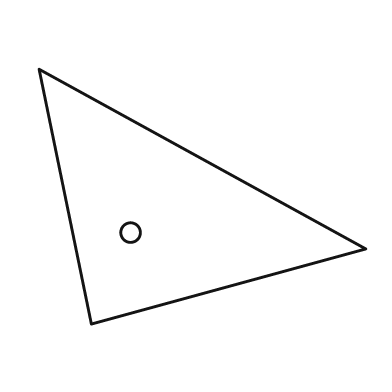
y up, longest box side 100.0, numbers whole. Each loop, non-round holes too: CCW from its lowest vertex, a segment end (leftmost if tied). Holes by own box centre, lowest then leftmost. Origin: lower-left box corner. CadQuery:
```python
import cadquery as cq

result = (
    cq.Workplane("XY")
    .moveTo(16.0, 0.0)
    .lineTo(100.0, 23.0)
    .lineTo(0.0, 78.0)
    .close()
    .moveTo(28.0, 28.0)
    .circle(3.0)
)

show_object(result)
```